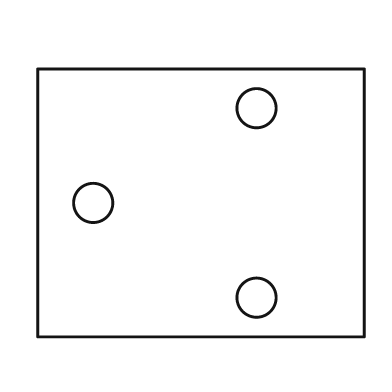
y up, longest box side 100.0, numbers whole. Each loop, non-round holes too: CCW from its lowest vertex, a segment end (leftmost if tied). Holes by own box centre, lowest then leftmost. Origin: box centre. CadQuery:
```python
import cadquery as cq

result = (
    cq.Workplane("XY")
    .moveTo(-50.0, -41.0)
    .lineTo(50.0, -41.0)
    .lineTo(50.0, 41.0)
    .lineTo(-50.0, 41.0)
    .close()
    .moveTo(17.0, -29.0)
    .circle(6.0)
    .moveTo(-33.0, 0.0)
    .circle(6.0)
    .moveTo(17.0, 29.0)
    .circle(6.0)
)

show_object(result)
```